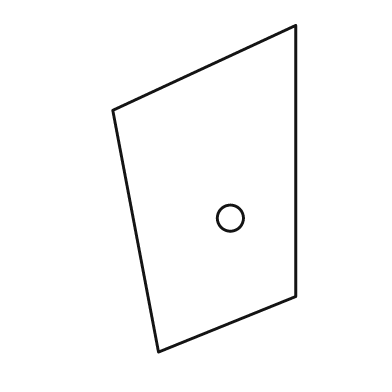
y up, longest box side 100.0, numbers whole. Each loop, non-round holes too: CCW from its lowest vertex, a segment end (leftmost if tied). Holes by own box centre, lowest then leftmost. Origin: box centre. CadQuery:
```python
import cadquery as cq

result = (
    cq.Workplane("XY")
    .moveTo(-14.0, -50.0)
    .lineTo(28.0, -33.0)
    .lineTo(28.0, 50.0)
    .lineTo(-28.0, 24.0)
    .close()
    .moveTo(8.0, -9.0)
    .circle(4.0)
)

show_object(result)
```